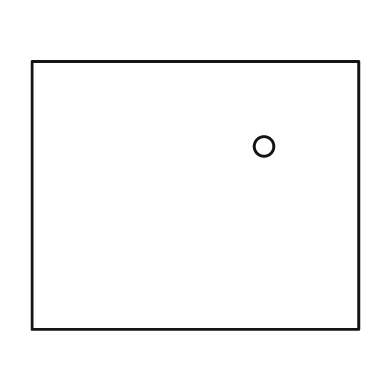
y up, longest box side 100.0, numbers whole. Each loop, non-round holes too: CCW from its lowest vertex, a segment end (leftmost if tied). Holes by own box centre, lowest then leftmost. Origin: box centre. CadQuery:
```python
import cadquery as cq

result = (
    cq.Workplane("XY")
    .moveTo(-50.0, -41.0)
    .lineTo(50.0, -41.0)
    .lineTo(50.0, 41.0)
    .lineTo(-50.0, 41.0)
    .close()
    .moveTo(21.0, 15.0)
    .circle(3.0)
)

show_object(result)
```